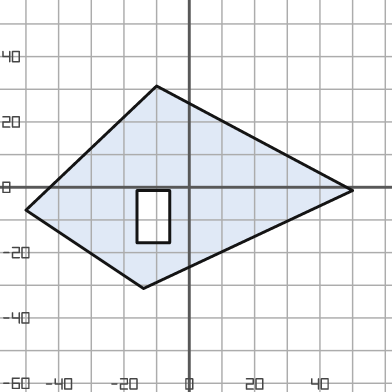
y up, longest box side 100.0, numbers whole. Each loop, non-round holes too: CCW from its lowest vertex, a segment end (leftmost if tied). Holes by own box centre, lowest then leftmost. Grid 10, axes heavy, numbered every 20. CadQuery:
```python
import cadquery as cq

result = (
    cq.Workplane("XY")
    .moveTo(-14.0, -31.0)
    .lineTo(50.0, -1.0)
    .lineTo(-10.0, 31.0)
    .lineTo(-50.0, -7.0)
    .close()
    .moveTo(-16.0, -17.0)
    .lineTo(-6.0, -17.0)
    .lineTo(-6.0, -1.0)
    .lineTo(-16.0, -1.0)
    .close()
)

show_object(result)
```